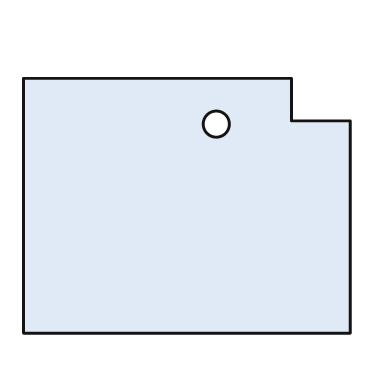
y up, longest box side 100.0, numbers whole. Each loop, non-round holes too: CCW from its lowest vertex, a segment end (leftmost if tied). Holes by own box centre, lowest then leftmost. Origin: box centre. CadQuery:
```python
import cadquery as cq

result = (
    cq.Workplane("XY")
    .moveTo(-50.0, -39.0)
    .lineTo(50.0, -39.0)
    .lineTo(50.0, 26.0)
    .lineTo(32.0, 26.0)
    .lineTo(32.0, 39.0)
    .lineTo(-50.0, 39.0)
    .close()
    .moveTo(9.0, 25.0)
    .circle(4.0)
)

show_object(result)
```